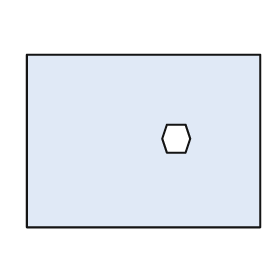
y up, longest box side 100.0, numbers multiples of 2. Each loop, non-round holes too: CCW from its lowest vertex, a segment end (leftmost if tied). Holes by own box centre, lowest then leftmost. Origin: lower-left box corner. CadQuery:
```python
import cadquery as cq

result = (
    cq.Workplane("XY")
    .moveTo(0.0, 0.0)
    .lineTo(100.0, 0.0)
    .lineTo(100.0, 74.0)
    .lineTo(0.0, 74.0)
    .close()
    .moveTo(60.0, 32.0)
    .lineTo(68.0, 32.0)
    .lineTo(70.0, 38.0)
    .lineTo(68.0, 44.0)
    .lineTo(60.0, 44.0)
    .lineTo(58.0, 38.0)
    .close()
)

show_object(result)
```